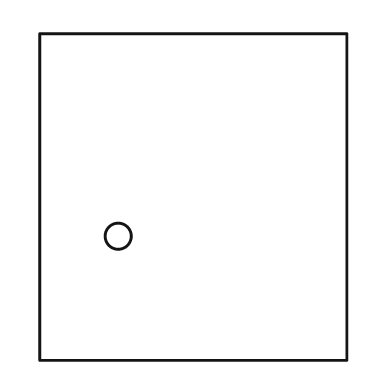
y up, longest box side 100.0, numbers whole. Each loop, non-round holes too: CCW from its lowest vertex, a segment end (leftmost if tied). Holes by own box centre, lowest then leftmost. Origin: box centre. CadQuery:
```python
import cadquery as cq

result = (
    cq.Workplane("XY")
    .moveTo(-47.0, -50.0)
    .lineTo(47.0, -50.0)
    .lineTo(47.0, 50.0)
    .lineTo(-47.0, 50.0)
    .close()
    .moveTo(-23.0, -12.0)
    .circle(4.0)
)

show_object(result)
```